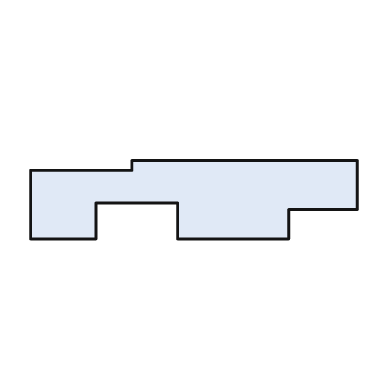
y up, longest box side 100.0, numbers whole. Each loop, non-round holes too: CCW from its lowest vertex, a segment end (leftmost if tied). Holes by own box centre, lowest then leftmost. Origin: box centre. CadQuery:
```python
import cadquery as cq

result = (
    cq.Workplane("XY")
    .moveTo(-50.0, -12.0)
    .lineTo(-30.0, -12.0)
    .lineTo(-30.0, -1.0)
    .lineTo(-5.0, -1.0)
    .lineTo(-5.0, -12.0)
    .lineTo(29.0, -12.0)
    .lineTo(29.0, -3.0)
    .lineTo(50.0, -3.0)
    .lineTo(50.0, 12.0)
    .lineTo(-19.0, 12.0)
    .lineTo(-19.0, 9.0)
    .lineTo(-50.0, 9.0)
    .close()
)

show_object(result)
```